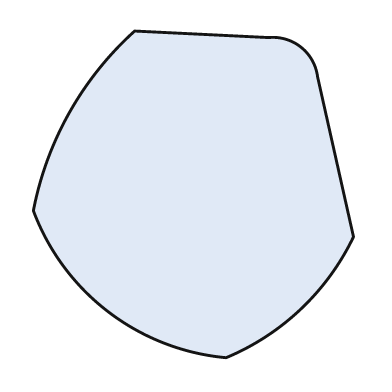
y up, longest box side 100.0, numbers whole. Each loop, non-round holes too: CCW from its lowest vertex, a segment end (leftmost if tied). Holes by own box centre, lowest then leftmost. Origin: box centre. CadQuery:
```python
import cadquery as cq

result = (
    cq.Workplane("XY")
    .moveTo(10.0, -50.0)
    .threePointArc((33.0, -35.0), (49.0, -13.0))
    .lineTo(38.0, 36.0)
    .threePointArc((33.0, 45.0), (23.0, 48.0))
    .lineTo(-18.0, 50.0)
    .threePointArc((-38.0, 25.0), (-49.0, -5.0))
    .threePointArc((-26.0, -36.0), (10.0, -50.0))
    .close()
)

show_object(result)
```